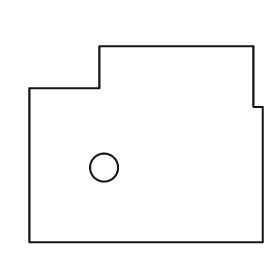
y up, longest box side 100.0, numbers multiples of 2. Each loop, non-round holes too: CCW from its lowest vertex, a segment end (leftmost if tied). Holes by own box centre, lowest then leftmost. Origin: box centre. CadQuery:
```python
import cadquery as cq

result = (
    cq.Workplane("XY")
    .moveTo(-50.0, -42.0)
    .lineTo(50.0, -42.0)
    .lineTo(50.0, 16.0)
    .lineTo(46.0, 16.0)
    .lineTo(46.0, 42.0)
    .lineTo(-20.0, 42.0)
    .lineTo(-20.0, 24.0)
    .lineTo(-50.0, 24.0)
    .close()
    .moveTo(-18.0, -10.0)
    .circle(6.0)
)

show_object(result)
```